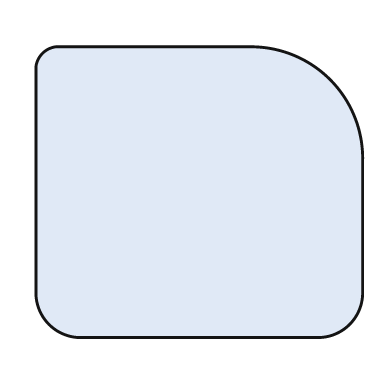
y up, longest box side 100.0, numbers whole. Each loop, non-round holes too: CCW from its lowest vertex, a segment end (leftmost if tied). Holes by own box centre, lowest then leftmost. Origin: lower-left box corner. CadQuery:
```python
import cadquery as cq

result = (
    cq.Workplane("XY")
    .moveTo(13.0, 0.0)
    .lineTo(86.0, 0.0)
    .threePointArc((96.0, 4.0), (100.0, 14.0))
    .lineTo(100.0, 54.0)
    .threePointArc((90.0, 79.0), (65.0, 89.0))
    .lineTo(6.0, 89.0)
    .threePointArc((2.0, 87.0), (0.0, 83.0))
    .lineTo(0.0, 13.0)
    .threePointArc((4.0, 4.0), (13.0, 0.0))
    .close()
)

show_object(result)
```